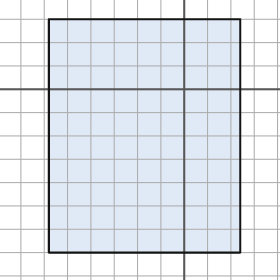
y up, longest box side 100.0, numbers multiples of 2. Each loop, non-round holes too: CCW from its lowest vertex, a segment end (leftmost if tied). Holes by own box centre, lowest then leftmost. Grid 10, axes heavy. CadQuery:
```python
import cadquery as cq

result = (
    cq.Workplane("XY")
    .moveTo(-58.0, -70.0)
    .lineTo(24.0, -70.0)
    .lineTo(24.0, 30.0)
    .lineTo(-58.0, 30.0)
    .close()
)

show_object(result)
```